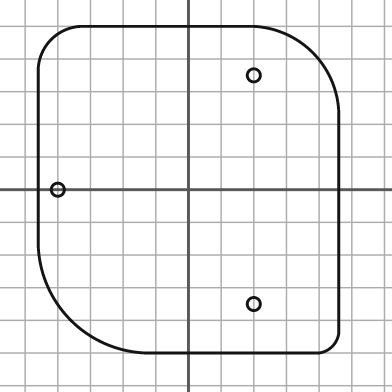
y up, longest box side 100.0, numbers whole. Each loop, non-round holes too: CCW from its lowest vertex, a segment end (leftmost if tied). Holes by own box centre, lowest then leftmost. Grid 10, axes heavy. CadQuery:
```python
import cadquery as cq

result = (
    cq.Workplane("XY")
    .moveTo(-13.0, -50.0)
    .lineTo(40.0, -50.0)
    .threePointArc((44.0, -48.0), (46.0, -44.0))
    .lineTo(46.0, 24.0)
    .threePointArc((38.0, 42.0), (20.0, 50.0))
    .lineTo(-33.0, 50.0)
    .threePointArc((-42.0, 46.0), (-46.0, 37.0))
    .lineTo(-46.0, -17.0)
    .threePointArc((-36.0, -40.0), (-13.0, -50.0))
    .close()
    .moveTo(20.0, -35.0)
    .circle(2.0)
    .moveTo(-40.0, 0.0)
    .circle(2.0)
    .moveTo(20.0, 35.0)
    .circle(2.0)
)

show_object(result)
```